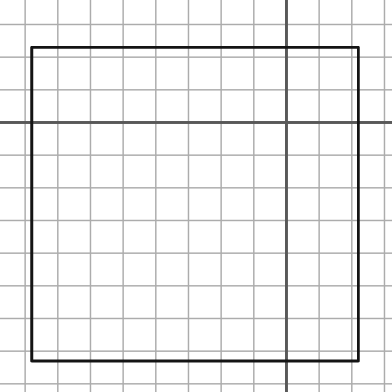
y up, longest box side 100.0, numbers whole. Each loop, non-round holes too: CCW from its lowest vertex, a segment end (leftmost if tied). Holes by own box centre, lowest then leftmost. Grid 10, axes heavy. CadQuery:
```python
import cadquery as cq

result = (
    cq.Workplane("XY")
    .moveTo(-78.0, -73.0)
    .lineTo(22.0, -73.0)
    .lineTo(22.0, 23.0)
    .lineTo(-78.0, 23.0)
    .close()
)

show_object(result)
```